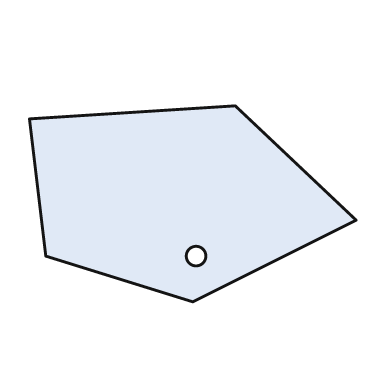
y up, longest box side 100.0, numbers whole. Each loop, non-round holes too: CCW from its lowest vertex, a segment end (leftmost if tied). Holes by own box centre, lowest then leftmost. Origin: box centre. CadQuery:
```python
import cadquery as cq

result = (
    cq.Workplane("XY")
    .moveTo(0.0, -30.0)
    .lineTo(50.0, -5.0)
    .lineTo(13.0, 30.0)
    .lineTo(-50.0, 26.0)
    .lineTo(-45.0, -16.0)
    .close()
    .moveTo(1.0, -16.0)
    .circle(3.0)
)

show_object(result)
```